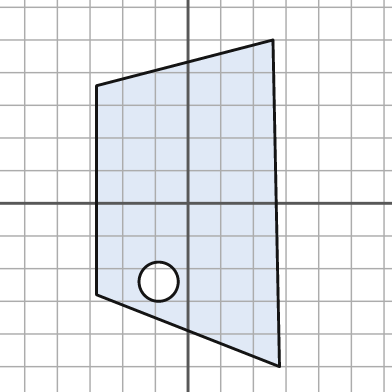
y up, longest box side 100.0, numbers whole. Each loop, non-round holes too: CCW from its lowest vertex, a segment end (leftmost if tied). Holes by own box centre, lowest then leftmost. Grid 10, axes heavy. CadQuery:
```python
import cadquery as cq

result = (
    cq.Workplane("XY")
    .moveTo(28.0, -50.0)
    .lineTo(26.0, 50.0)
    .lineTo(-28.0, 36.0)
    .lineTo(-28.0, -28.0)
    .close()
    .moveTo(-9.0, -24.0)
    .circle(6.0)
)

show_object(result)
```